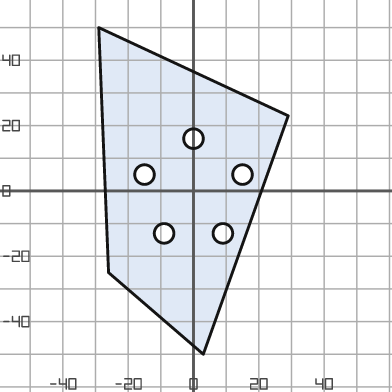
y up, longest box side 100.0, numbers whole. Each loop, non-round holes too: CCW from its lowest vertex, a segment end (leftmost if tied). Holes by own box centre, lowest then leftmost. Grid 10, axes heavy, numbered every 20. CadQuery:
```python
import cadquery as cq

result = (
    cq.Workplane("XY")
    .moveTo(3.0, -50.0)
    .lineTo(29.0, 23.0)
    .lineTo(-29.0, 50.0)
    .lineTo(-26.0, -25.0)
    .close()
    .moveTo(-9.0, -13.0)
    .circle(3.0)
    .moveTo(9.0, -13.0)
    .circle(3.0)
    .moveTo(-15.0, 5.0)
    .circle(3.0)
    .moveTo(15.0, 5.0)
    .circle(3.0)
    .moveTo(0.0, 16.0)
    .circle(3.0)
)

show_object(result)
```